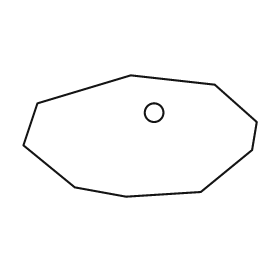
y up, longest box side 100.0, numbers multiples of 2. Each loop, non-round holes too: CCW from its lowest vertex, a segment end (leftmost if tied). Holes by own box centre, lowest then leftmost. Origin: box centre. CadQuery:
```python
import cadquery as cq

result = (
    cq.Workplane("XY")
    .moveTo(-6.0, -26.0)
    .lineTo(26.0, -24.0)
    .lineTo(48.0, -6.0)
    .lineTo(50.0, 6.0)
    .lineTo(32.0, 22.0)
    .lineTo(-4.0, 26.0)
    .lineTo(-44.0, 14.0)
    .lineTo(-50.0, -4.0)
    .lineTo(-28.0, -22.0)
    .close()
    .moveTo(6.0, 10.0)
    .circle(4.0)
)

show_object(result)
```